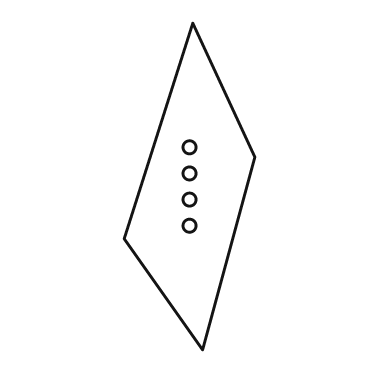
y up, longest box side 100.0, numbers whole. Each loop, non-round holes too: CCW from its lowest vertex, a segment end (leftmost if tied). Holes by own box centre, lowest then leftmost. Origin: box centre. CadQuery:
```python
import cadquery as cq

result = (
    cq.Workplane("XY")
    .moveTo(4.0, -50.0)
    .lineTo(20.0, 9.0)
    .lineTo(1.0, 50.0)
    .lineTo(-20.0, -16.0)
    .close()
    .moveTo(0.0, -12.0)
    .circle(2.0)
    .moveTo(0.0, -4.0)
    .circle(2.0)
    .moveTo(0.0, 4.0)
    .circle(2.0)
    .moveTo(0.0, 12.0)
    .circle(2.0)
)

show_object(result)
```